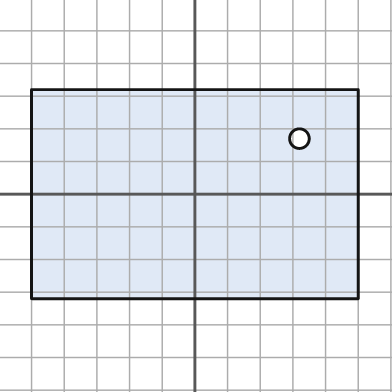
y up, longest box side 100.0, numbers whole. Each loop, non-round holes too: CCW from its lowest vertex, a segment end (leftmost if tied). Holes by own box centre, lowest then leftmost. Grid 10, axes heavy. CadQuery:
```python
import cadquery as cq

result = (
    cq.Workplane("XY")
    .moveTo(-50.0, -32.0)
    .lineTo(50.0, -32.0)
    .lineTo(50.0, 32.0)
    .lineTo(-50.0, 32.0)
    .close()
    .moveTo(32.0, 17.0)
    .circle(3.0)
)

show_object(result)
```